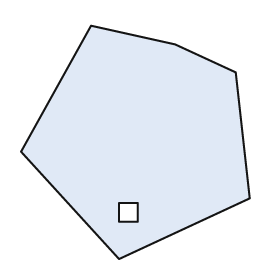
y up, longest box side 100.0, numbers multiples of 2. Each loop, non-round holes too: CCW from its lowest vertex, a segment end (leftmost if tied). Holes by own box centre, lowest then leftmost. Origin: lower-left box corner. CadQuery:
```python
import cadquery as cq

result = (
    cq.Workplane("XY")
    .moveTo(42.0, 0.0)
    .lineTo(98.0, 26.0)
    .lineTo(92.0, 80.0)
    .lineTo(66.0, 92.0)
    .lineTo(30.0, 100.0)
    .lineTo(0.0, 46.0)
    .close()
    .moveTo(42.0, 16.0)
    .lineTo(50.0, 16.0)
    .lineTo(50.0, 24.0)
    .lineTo(42.0, 24.0)
    .close()
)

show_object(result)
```